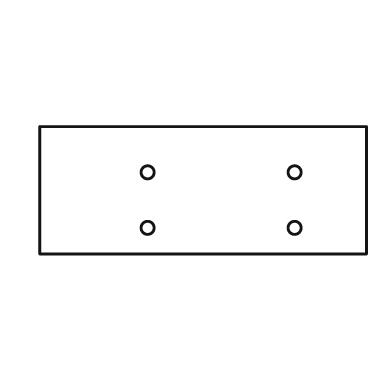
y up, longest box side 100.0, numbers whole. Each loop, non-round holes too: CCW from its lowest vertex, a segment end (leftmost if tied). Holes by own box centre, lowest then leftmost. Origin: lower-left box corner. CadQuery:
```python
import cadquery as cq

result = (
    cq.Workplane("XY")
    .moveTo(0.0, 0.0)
    .lineTo(100.0, 0.0)
    .lineTo(100.0, 39.0)
    .lineTo(0.0, 39.0)
    .close()
    .moveTo(33.0, 8.0)
    .circle(2.0)
    .moveTo(78.0, 8.0)
    .circle(2.0)
    .moveTo(33.0, 25.0)
    .circle(2.0)
    .moveTo(78.0, 25.0)
    .circle(2.0)
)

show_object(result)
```